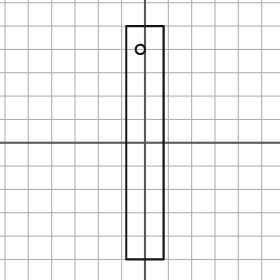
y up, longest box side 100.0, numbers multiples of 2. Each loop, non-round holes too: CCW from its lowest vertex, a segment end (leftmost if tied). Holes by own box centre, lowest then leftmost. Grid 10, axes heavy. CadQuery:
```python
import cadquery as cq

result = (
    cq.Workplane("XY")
    .moveTo(-8.0, -50.0)
    .lineTo(8.0, -50.0)
    .lineTo(8.0, 50.0)
    .lineTo(-8.0, 50.0)
    .close()
    .moveTo(-2.0, 40.0)
    .circle(2.0)
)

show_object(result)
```